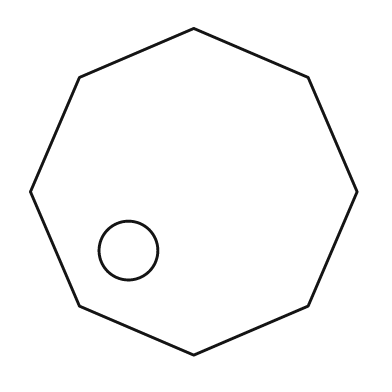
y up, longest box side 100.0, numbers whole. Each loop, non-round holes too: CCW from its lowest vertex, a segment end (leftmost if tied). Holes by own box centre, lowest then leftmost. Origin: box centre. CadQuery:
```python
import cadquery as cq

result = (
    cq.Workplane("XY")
    .moveTo(0.0, -50.0)
    .lineTo(35.0, -35.0)
    .lineTo(50.0, 0.0)
    .lineTo(35.0, 35.0)
    .lineTo(0.0, 50.0)
    .lineTo(-35.0, 35.0)
    .lineTo(-50.0, 0.0)
    .lineTo(-35.0, -35.0)
    .close()
    .moveTo(-20.0, -18.0)
    .circle(9.0)
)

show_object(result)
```